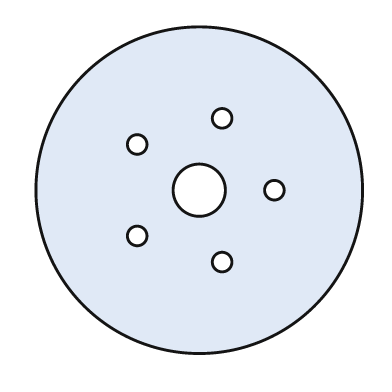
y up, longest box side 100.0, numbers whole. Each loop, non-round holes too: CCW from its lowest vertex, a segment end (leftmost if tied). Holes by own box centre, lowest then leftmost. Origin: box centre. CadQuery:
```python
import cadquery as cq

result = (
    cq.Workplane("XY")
    .moveTo(0.0, 0.0)
    .circle(50.0)
    .moveTo(7.0, -22.0)
    .circle(3.0)
    .moveTo(-19.0, -14.0)
    .circle(3.0)
    .moveTo(0.0, 0.0)
    .circle(8.0)
    .moveTo(23.0, 0.0)
    .circle(3.0)
    .moveTo(-19.0, 14.0)
    .circle(3.0)
    .moveTo(7.0, 22.0)
    .circle(3.0)
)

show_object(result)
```